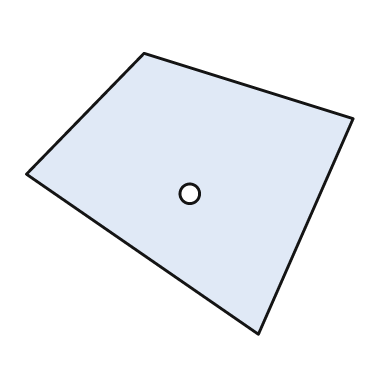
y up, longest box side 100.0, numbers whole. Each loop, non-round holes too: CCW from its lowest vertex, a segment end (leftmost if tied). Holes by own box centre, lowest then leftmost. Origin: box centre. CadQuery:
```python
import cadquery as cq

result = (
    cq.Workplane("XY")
    .moveTo(21.0, -43.0)
    .lineTo(50.0, 23.0)
    .lineTo(-14.0, 43.0)
    .lineTo(-50.0, 6.0)
    .close()
    .moveTo(0.0, 0.0)
    .circle(3.0)
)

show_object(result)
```